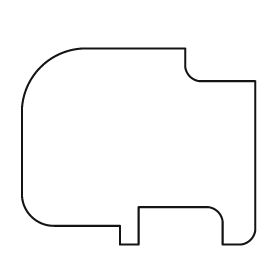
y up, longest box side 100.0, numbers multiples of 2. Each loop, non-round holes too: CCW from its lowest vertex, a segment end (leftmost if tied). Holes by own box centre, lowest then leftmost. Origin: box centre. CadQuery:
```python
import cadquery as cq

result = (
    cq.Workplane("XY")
    .moveTo(-8.0, -42.0)
    .lineTo(0.0, -42.0)
    .lineTo(0.0, -26.0)
    .lineTo(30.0, -26.0)
    .threePointArc((34.0, -28.0), (36.0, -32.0))
    .lineTo(36.0, -42.0)
    .lineTo(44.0, -42.0)
    .threePointArc((48.0, -40.0), (50.0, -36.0))
    .lineTo(50.0, 28.0)
    .lineTo(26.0, 28.0)
    .threePointArc((22.0, 30.0), (20.0, 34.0))
    .lineTo(20.0, 42.0)
    .lineTo(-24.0, 42.0)
    .threePointArc((-42.0, 34.0), (-50.0, 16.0))
    .lineTo(-50.0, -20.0)
    .threePointArc((-46.0, -30.0), (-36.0, -34.0))
    .lineTo(-8.0, -34.0)
    .close()
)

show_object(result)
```